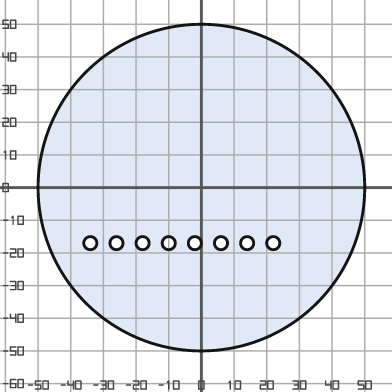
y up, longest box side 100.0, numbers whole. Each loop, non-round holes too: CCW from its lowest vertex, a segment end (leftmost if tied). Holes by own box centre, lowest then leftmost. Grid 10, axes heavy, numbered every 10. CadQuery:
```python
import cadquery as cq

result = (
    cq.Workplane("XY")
    .moveTo(0.0, 0.0)
    .circle(50.0)
    .moveTo(-34.0, -17.0)
    .circle(2.0)
    .moveTo(-26.0, -17.0)
    .circle(2.0)
    .moveTo(-18.0, -17.0)
    .circle(2.0)
    .moveTo(-10.0, -17.0)
    .circle(2.0)
    .moveTo(-2.0, -17.0)
    .circle(2.0)
    .moveTo(6.0, -17.0)
    .circle(2.0)
    .moveTo(14.0, -17.0)
    .circle(2.0)
    .moveTo(22.0, -17.0)
    .circle(2.0)
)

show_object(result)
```